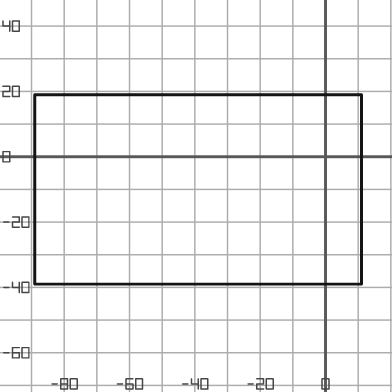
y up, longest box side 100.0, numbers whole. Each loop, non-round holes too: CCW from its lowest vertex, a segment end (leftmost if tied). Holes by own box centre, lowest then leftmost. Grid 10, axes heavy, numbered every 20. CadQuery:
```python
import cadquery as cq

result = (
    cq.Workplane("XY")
    .moveTo(-89.0, -39.0)
    .lineTo(11.0, -39.0)
    .lineTo(11.0, 19.0)
    .lineTo(-89.0, 19.0)
    .close()
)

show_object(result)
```